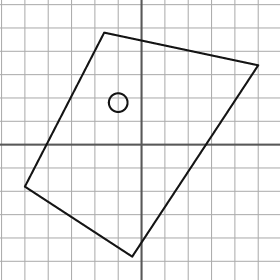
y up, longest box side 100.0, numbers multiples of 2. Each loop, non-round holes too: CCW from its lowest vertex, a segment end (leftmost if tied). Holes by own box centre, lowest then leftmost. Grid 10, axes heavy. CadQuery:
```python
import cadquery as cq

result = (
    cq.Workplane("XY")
    .moveTo(-4.0, -48.0)
    .lineTo(50.0, 34.0)
    .lineTo(-16.0, 48.0)
    .lineTo(-50.0, -18.0)
    .close()
    .moveTo(-10.0, 18.0)
    .circle(4.0)
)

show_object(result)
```